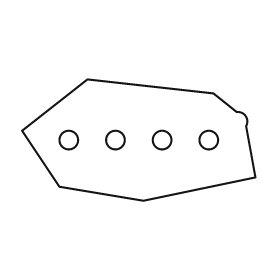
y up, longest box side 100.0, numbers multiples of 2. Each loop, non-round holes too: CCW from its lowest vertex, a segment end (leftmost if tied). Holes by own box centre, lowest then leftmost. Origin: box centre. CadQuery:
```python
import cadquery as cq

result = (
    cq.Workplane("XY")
    .moveTo(2.0, -26.0)
    .lineTo(50.0, -16.0)
    .lineTo(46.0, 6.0)
    .threePointArc((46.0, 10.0), (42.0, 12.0))
    .lineTo(32.0, 20.0)
    .lineTo(-22.0, 26.0)
    .lineTo(-50.0, 4.0)
    .lineTo(-34.0, -20.0)
    .close()
    .moveTo(-30.0, 0.0)
    .circle(4.0)
    .moveTo(-10.0, 0.0)
    .circle(4.0)
    .moveTo(10.0, 0.0)
    .circle(4.0)
    .moveTo(30.0, 0.0)
    .circle(4.0)
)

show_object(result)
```